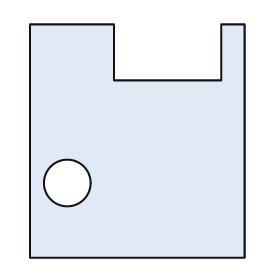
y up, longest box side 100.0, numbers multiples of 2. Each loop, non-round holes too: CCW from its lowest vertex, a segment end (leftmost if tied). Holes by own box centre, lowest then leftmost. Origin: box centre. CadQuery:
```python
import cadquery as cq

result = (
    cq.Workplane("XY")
    .moveTo(-46.0, -50.0)
    .lineTo(46.0, -50.0)
    .lineTo(46.0, 50.0)
    .lineTo(36.0, 50.0)
    .lineTo(36.0, 26.0)
    .lineTo(-10.0, 26.0)
    .lineTo(-10.0, 50.0)
    .lineTo(-46.0, 50.0)
    .close()
    .moveTo(-30.0, -18.0)
    .circle(10.0)
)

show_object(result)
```